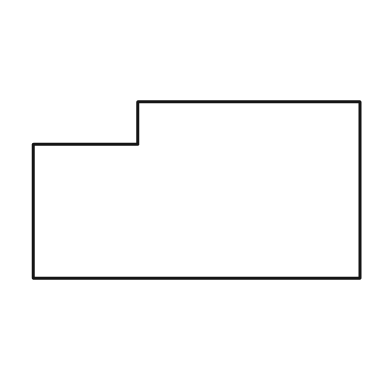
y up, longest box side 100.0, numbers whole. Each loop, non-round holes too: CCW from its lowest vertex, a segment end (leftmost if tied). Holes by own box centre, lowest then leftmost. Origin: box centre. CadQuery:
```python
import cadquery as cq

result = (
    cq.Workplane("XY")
    .moveTo(-50.0, -27.0)
    .lineTo(50.0, -27.0)
    .lineTo(50.0, 27.0)
    .lineTo(-18.0, 27.0)
    .lineTo(-18.0, 14.0)
    .lineTo(-50.0, 14.0)
    .close()
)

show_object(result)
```